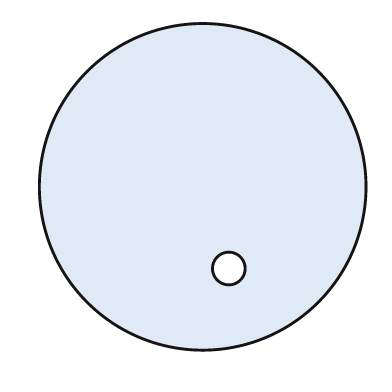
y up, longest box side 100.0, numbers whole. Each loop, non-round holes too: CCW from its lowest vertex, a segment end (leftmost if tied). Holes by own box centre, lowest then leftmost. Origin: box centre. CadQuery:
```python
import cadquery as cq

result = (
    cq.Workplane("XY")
    .moveTo(0.0, 0.0)
    .circle(50.0)
    .moveTo(8.0, -25.0)
    .circle(5.0)
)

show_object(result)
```